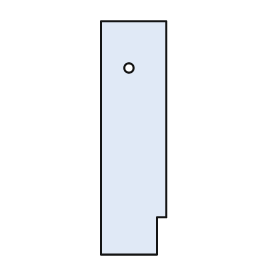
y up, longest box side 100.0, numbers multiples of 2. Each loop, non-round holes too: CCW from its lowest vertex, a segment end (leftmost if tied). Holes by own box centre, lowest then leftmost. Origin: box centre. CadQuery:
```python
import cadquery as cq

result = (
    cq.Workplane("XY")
    .moveTo(-14.0, -50.0)
    .lineTo(10.0, -50.0)
    .lineTo(10.0, -34.0)
    .lineTo(14.0, -34.0)
    .lineTo(14.0, 50.0)
    .lineTo(-14.0, 50.0)
    .close()
    .moveTo(-2.0, 30.0)
    .circle(2.0)
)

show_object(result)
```